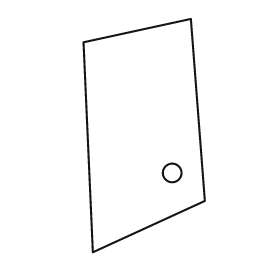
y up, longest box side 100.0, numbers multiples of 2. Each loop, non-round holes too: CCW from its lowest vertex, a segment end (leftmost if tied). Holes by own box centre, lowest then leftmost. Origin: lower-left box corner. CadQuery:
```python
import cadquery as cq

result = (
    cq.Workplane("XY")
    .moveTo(4.0, 0.0)
    .lineTo(52.0, 22.0)
    .lineTo(46.0, 100.0)
    .lineTo(0.0, 90.0)
    .close()
    .moveTo(38.0, 34.0)
    .circle(4.0)
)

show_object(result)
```